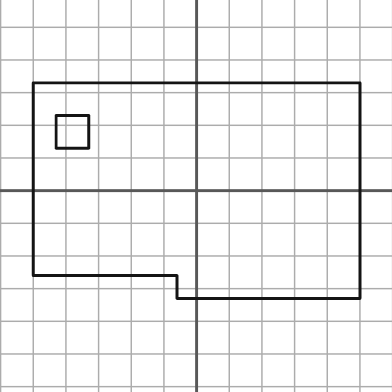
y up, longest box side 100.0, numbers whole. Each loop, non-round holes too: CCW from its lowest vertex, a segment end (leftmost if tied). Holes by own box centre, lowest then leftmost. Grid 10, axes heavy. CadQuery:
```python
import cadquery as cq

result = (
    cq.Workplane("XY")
    .moveTo(-6.0, -33.0)
    .lineTo(50.0, -33.0)
    .lineTo(50.0, 33.0)
    .lineTo(-50.0, 33.0)
    .lineTo(-50.0, -26.0)
    .lineTo(-6.0, -26.0)
    .close()
    .moveTo(-43.0, 13.0)
    .lineTo(-33.0, 13.0)
    .lineTo(-33.0, 23.0)
    .lineTo(-43.0, 23.0)
    .close()
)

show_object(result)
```